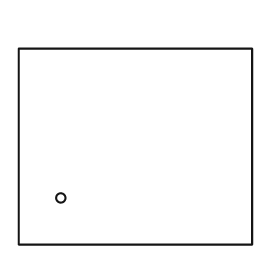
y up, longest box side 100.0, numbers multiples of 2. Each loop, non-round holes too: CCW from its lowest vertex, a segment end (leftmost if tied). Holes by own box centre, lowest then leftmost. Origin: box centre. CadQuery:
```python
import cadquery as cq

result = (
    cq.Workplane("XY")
    .moveTo(-50.0, -42.0)
    .lineTo(50.0, -42.0)
    .lineTo(50.0, 42.0)
    .lineTo(-50.0, 42.0)
    .close()
    .moveTo(-32.0, -22.0)
    .circle(2.0)
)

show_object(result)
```